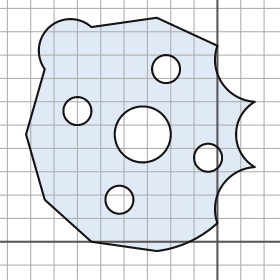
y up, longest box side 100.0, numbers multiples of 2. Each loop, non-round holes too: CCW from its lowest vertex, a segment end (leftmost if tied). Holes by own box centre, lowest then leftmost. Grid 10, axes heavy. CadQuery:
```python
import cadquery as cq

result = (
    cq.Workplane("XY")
    .moveTo(-26.0, -4.0)
    .threePointArc((-12.0, 0.0), (0.0, 8.0))
    .threePointArc((2.0, 24.0), (16.0, 32.0))
    .threePointArc((8.0, 46.0), (16.0, 60.0))
    .threePointArc((2.0, 68.0), (0.0, 84.0))
    .lineTo(-26.0, 96.0)
    .lineTo(-54.0, 92.0)
    .threePointArc((-72.0, 92.0), (-74.0, 74.0))
    .lineTo(-82.0, 46.0)
    .lineTo(-74.0, 18.0)
    .lineTo(-54.0, 0.0)
    .close()
    .moveTo(-42.0, 18.0)
    .circle(6.0)
    .moveTo(-4.0, 36.0)
    .circle(6.0)
    .moveTo(-32.0, 46.0)
    .circle(12.0)
    .moveTo(-60.0, 56.0)
    .circle(6.0)
    .moveTo(-22.0, 74.0)
    .circle(6.0)
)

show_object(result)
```